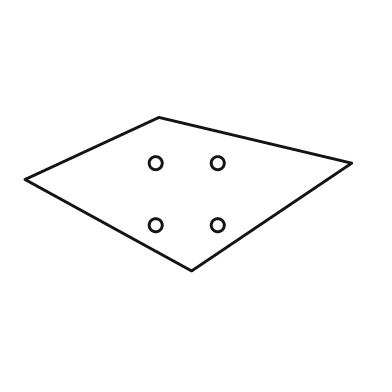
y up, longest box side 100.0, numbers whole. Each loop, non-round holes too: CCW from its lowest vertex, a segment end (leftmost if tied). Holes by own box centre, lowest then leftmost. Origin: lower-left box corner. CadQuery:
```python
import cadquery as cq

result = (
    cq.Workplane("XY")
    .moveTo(51.0, 0.0)
    .lineTo(100.0, 33.0)
    .lineTo(41.0, 47.0)
    .lineTo(0.0, 28.0)
    .close()
    .moveTo(40.0, 14.0)
    .circle(2.0)
    .moveTo(59.0, 14.0)
    .circle(2.0)
    .moveTo(40.0, 33.0)
    .circle(2.0)
    .moveTo(59.0, 33.0)
    .circle(2.0)
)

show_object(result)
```